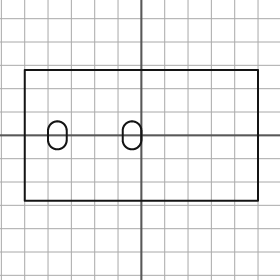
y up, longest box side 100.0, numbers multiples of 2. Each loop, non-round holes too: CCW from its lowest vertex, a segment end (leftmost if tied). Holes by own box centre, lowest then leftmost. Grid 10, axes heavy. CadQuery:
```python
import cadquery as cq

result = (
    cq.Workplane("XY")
    .moveTo(-50.0, -28.0)
    .lineTo(50.0, -28.0)
    .lineTo(50.0, 28.0)
    .lineTo(-50.0, 28.0)
    .close()
    .moveTo(-40.0, -2.0)
    .threePointArc((-36.0, -6.0), (-32.0, -2.0))
    .lineTo(-32.0, 2.0)
    .threePointArc((-36.0, 6.0), (-40.0, 2.0))
    .close()
    .moveTo(-8.0, -2.0)
    .threePointArc((-4.0, -6.0), (0.0, -2.0))
    .lineTo(0.0, 2.0)
    .threePointArc((-4.0, 6.0), (-8.0, 2.0))
    .close()
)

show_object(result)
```